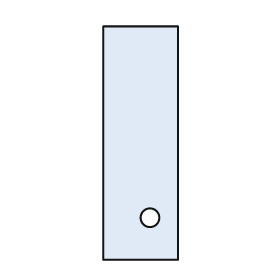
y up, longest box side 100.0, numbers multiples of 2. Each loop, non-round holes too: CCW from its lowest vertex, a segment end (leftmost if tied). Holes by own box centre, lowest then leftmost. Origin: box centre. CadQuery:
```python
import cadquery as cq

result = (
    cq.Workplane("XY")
    .moveTo(-16.0, -50.0)
    .lineTo(16.0, -50.0)
    .lineTo(16.0, 50.0)
    .lineTo(-16.0, 50.0)
    .close()
    .moveTo(4.0, -32.0)
    .circle(4.0)
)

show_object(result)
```